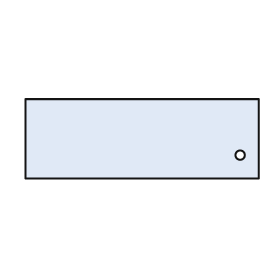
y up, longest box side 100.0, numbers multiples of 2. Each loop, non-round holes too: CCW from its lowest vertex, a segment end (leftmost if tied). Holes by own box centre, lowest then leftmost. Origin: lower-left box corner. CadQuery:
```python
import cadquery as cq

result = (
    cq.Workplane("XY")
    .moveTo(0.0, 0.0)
    .lineTo(100.0, 0.0)
    .lineTo(100.0, 34.0)
    .lineTo(0.0, 34.0)
    .close()
    .moveTo(92.0, 10.0)
    .circle(2.0)
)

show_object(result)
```